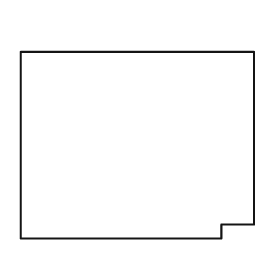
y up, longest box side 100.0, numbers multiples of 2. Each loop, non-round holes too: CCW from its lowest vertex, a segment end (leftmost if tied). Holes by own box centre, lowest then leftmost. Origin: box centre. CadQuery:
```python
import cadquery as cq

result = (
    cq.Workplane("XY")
    .moveTo(-50.0, -40.0)
    .lineTo(36.0, -40.0)
    .lineTo(36.0, -34.0)
    .lineTo(50.0, -34.0)
    .lineTo(50.0, 40.0)
    .lineTo(-50.0, 40.0)
    .close()
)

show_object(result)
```